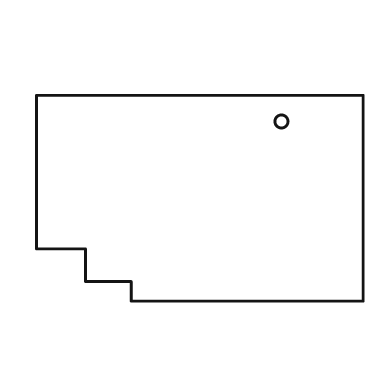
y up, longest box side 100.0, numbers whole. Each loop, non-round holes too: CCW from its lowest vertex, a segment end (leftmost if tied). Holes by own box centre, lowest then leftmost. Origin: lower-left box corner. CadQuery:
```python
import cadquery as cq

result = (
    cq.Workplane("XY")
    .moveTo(29.0, 0.0)
    .lineTo(100.0, 0.0)
    .lineTo(100.0, 63.0)
    .lineTo(0.0, 63.0)
    .lineTo(0.0, 16.0)
    .lineTo(15.0, 16.0)
    .lineTo(15.0, 6.0)
    .lineTo(29.0, 6.0)
    .close()
    .moveTo(75.0, 55.0)
    .circle(2.0)
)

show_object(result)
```